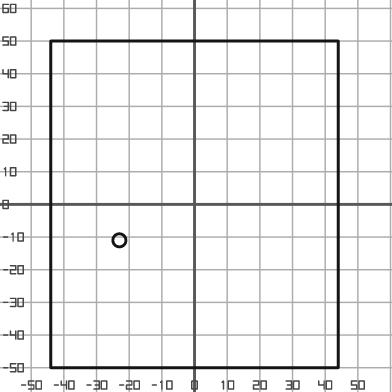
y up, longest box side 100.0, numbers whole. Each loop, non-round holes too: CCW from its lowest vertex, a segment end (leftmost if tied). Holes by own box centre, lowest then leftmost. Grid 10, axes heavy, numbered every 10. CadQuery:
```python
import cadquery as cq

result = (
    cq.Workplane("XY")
    .moveTo(-44.0, -50.0)
    .lineTo(44.0, -50.0)
    .lineTo(44.0, 50.0)
    .lineTo(-44.0, 50.0)
    .close()
    .moveTo(-23.0, -11.0)
    .circle(2.0)
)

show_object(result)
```